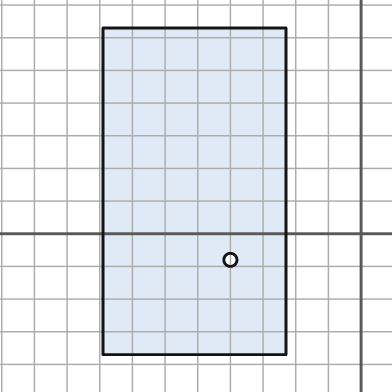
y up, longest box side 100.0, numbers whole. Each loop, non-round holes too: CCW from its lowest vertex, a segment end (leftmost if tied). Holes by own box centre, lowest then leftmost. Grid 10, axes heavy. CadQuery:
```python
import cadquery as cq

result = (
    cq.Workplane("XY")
    .moveTo(-79.0, -37.0)
    .lineTo(-23.0, -37.0)
    .lineTo(-23.0, 63.0)
    .lineTo(-79.0, 63.0)
    .close()
    .moveTo(-40.0, -8.0)
    .circle(2.0)
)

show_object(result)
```